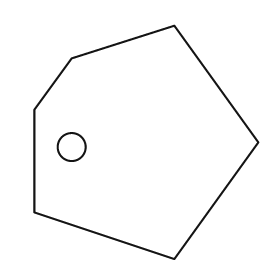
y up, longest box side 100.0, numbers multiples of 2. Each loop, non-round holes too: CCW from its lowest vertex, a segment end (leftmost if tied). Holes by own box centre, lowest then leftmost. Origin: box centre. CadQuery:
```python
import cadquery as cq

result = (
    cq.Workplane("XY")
    .moveTo(12.0, -50.0)
    .lineTo(48.0, 0.0)
    .lineTo(12.0, 50.0)
    .lineTo(-32.0, 36.0)
    .lineTo(-48.0, 14.0)
    .lineTo(-48.0, -30.0)
    .close()
    .moveTo(-32.0, -2.0)
    .circle(6.0)
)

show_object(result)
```